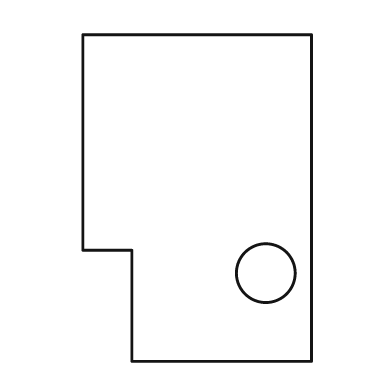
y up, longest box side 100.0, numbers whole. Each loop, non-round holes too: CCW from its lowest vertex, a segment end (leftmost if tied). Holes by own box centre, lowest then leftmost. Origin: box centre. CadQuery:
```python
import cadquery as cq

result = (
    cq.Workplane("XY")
    .moveTo(-20.0, -50.0)
    .lineTo(35.0, -50.0)
    .lineTo(35.0, 50.0)
    .lineTo(-35.0, 50.0)
    .lineTo(-35.0, -16.0)
    .lineTo(-20.0, -16.0)
    .close()
    .moveTo(21.0, -23.0)
    .circle(9.0)
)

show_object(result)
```